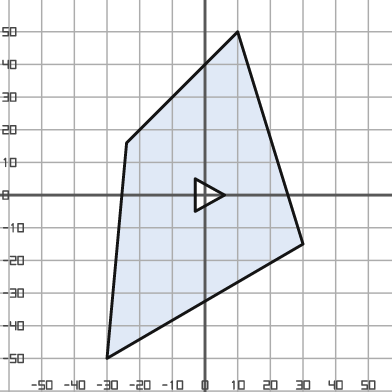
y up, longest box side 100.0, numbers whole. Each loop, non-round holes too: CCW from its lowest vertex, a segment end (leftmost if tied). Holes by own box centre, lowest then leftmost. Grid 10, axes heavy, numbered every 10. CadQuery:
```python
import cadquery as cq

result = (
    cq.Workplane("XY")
    .moveTo(-30.0, -50.0)
    .lineTo(30.0, -15.0)
    .lineTo(10.0, 50.0)
    .lineTo(-24.0, 16.0)
    .close()
    .moveTo(-3.0, -5.0)
    .lineTo(6.0, 0.0)
    .lineTo(-3.0, 5.0)
    .close()
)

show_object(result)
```